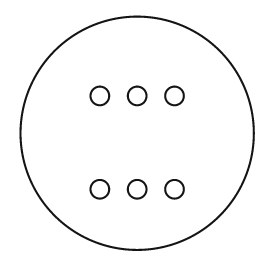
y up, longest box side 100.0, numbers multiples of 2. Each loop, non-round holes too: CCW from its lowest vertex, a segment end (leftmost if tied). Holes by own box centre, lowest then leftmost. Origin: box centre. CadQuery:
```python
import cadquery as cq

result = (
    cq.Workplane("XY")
    .moveTo(0.0, 0.0)
    .circle(50.0)
    .moveTo(-16.0, -24.0)
    .circle(4.0)
    .moveTo(0.0, -24.0)
    .circle(4.0)
    .moveTo(16.0, -24.0)
    .circle(4.0)
    .moveTo(-16.0, 16.0)
    .circle(4.0)
    .moveTo(0.0, 16.0)
    .circle(4.0)
    .moveTo(16.0, 16.0)
    .circle(4.0)
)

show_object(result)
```